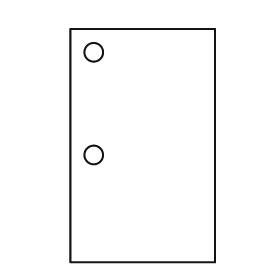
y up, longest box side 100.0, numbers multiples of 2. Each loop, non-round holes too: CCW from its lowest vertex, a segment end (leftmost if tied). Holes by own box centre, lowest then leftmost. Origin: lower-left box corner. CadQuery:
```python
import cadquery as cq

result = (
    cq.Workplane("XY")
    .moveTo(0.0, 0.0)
    .lineTo(62.0, 0.0)
    .lineTo(62.0, 100.0)
    .lineTo(0.0, 100.0)
    .close()
    .moveTo(10.0, 46.0)
    .circle(4.0)
    .moveTo(10.0, 90.0)
    .circle(4.0)
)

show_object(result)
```